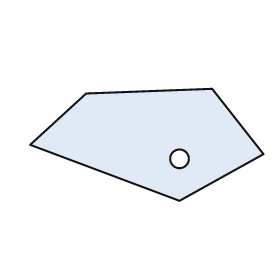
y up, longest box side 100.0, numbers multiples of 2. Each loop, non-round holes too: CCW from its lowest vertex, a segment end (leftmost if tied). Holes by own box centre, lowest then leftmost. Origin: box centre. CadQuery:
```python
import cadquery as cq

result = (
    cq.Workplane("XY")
    .moveTo(14.0, -24.0)
    .lineTo(50.0, -4.0)
    .lineTo(28.0, 24.0)
    .lineTo(-26.0, 22.0)
    .lineTo(-50.0, 0.0)
    .close()
    .moveTo(14.0, -6.0)
    .circle(4.0)
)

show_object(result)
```